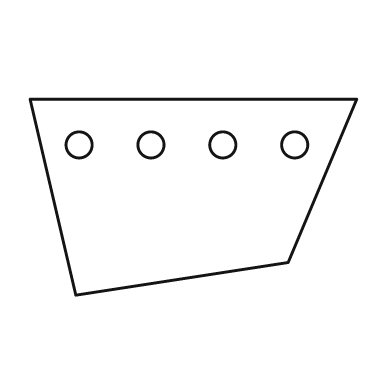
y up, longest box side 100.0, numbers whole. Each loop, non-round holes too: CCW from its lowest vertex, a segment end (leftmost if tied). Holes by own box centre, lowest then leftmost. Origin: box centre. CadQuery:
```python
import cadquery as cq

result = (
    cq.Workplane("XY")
    .moveTo(-36.0, -30.0)
    .lineTo(29.0, -20.0)
    .lineTo(50.0, 30.0)
    .lineTo(-50.0, 30.0)
    .close()
    .moveTo(-35.0, 16.0)
    .circle(4.0)
    .moveTo(-13.0, 16.0)
    .circle(4.0)
    .moveTo(9.0, 16.0)
    .circle(4.0)
    .moveTo(31.0, 16.0)
    .circle(4.0)
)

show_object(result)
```